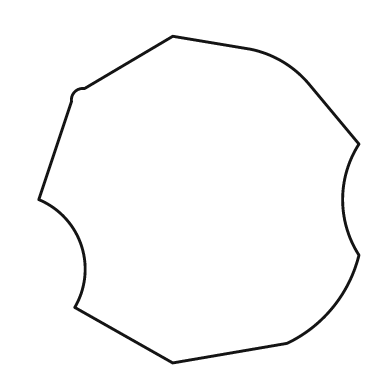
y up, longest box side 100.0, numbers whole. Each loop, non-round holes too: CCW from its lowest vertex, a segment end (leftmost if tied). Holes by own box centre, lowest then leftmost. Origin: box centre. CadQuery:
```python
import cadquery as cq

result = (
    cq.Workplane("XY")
    .moveTo(-8.0, -50.0)
    .lineTo(27.0, -44.0)
    .threePointArc((41.0, -33.0), (49.0, -17.0))
    .threePointArc((44.0, 0.0), (49.0, 17.0))
    .lineTo(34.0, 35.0)
    .threePointArc((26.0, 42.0), (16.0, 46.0))
    .lineTo(-8.0, 50.0)
    .lineTo(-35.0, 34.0)
    .threePointArc((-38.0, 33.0), (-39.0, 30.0))
    .lineTo(-49.0, 0.0)
    .threePointArc((-36.0, -14.0), (-38.0, -33.0))
    .close()
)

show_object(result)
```